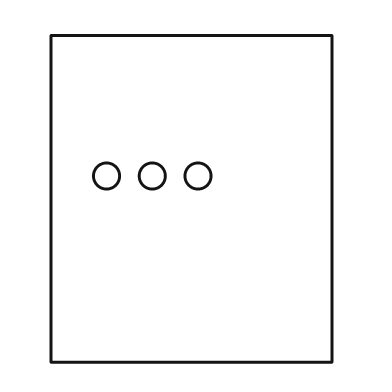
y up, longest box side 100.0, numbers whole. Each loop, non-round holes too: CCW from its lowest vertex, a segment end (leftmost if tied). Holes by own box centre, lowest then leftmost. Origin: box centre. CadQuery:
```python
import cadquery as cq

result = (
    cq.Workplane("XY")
    .moveTo(-43.0, -50.0)
    .lineTo(43.0, -50.0)
    .lineTo(43.0, 50.0)
    .lineTo(-43.0, 50.0)
    .close()
    .moveTo(-26.0, 7.0)
    .circle(4.0)
    .moveTo(-12.0, 7.0)
    .circle(4.0)
    .moveTo(2.0, 7.0)
    .circle(4.0)
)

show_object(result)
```